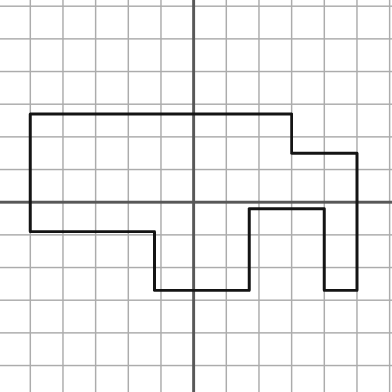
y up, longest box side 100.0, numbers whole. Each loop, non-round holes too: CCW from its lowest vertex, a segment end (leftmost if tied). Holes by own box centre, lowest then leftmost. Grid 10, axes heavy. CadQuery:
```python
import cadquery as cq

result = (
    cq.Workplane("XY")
    .moveTo(-12.0, -27.0)
    .lineTo(17.0, -27.0)
    .lineTo(17.0, -2.0)
    .lineTo(40.0, -2.0)
    .lineTo(40.0, -27.0)
    .lineTo(50.0, -27.0)
    .lineTo(50.0, 15.0)
    .lineTo(30.0, 15.0)
    .lineTo(30.0, 27.0)
    .lineTo(-50.0, 27.0)
    .lineTo(-50.0, -9.0)
    .lineTo(-12.0, -9.0)
    .close()
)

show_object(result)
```